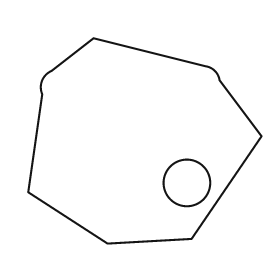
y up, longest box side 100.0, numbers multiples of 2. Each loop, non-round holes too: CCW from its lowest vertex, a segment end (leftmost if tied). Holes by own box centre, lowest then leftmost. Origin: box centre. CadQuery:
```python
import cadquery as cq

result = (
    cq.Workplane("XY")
    .moveTo(-16.0, -44.0)
    .lineTo(20.0, -42.0)
    .lineTo(50.0, 2.0)
    .lineTo(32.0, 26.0)
    .threePointArc((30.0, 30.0), (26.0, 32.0))
    .lineTo(-22.0, 44.0)
    .lineTo(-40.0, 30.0)
    .threePointArc((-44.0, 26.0), (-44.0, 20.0))
    .lineTo(-50.0, -22.0)
    .close()
    .moveTo(18.0, -18.0)
    .circle(10.0)
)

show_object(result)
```